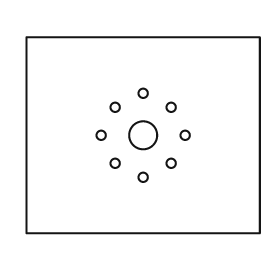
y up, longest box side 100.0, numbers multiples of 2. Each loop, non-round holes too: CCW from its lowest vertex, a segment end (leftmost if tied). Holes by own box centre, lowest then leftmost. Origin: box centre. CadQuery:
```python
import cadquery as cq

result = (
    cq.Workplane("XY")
    .moveTo(-50.0, -42.0)
    .lineTo(50.0, -42.0)
    .lineTo(50.0, 42.0)
    .lineTo(-50.0, 42.0)
    .close()
    .moveTo(0.0, -18.0)
    .circle(2.0)
    .moveTo(-12.0, -12.0)
    .circle(2.0)
    .moveTo(12.0, -12.0)
    .circle(2.0)
    .moveTo(-18.0, 0.0)
    .circle(2.0)
    .moveTo(0.0, 0.0)
    .circle(6.0)
    .moveTo(18.0, 0.0)
    .circle(2.0)
    .moveTo(-12.0, 12.0)
    .circle(2.0)
    .moveTo(12.0, 12.0)
    .circle(2.0)
    .moveTo(0.0, 18.0)
    .circle(2.0)
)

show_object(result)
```